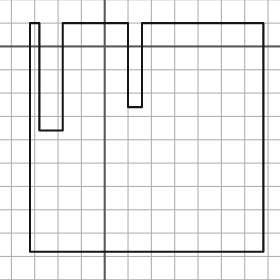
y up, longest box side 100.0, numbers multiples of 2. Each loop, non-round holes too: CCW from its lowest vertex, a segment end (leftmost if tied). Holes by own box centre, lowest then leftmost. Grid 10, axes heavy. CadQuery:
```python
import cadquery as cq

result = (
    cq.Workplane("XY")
    .moveTo(-32.0, -88.0)
    .lineTo(68.0, -88.0)
    .lineTo(68.0, 10.0)
    .lineTo(16.0, 10.0)
    .lineTo(16.0, -26.0)
    .lineTo(10.0, -26.0)
    .lineTo(10.0, 10.0)
    .lineTo(-18.0, 10.0)
    .lineTo(-18.0, -36.0)
    .lineTo(-28.0, -36.0)
    .lineTo(-28.0, 10.0)
    .lineTo(-32.0, 10.0)
    .close()
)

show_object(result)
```